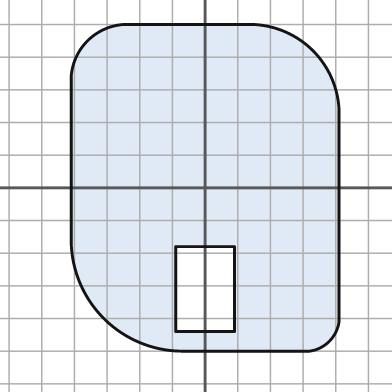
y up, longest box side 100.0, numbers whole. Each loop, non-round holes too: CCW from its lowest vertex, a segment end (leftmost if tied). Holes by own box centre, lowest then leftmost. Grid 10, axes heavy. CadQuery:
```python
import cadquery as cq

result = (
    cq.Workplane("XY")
    .moveTo(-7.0, -50.0)
    .lineTo(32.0, -50.0)
    .threePointArc((38.0, -47.0), (41.0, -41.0))
    .lineTo(41.0, 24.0)
    .threePointArc((33.0, 42.0), (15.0, 50.0))
    .lineTo(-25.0, 50.0)
    .threePointArc((-36.0, 45.0), (-41.0, 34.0))
    .lineTo(-41.0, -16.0)
    .threePointArc((-31.0, -40.0), (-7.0, -50.0))
    .close()
    .moveTo(-9.0, -44.0)
    .lineTo(9.0, -44.0)
    .lineTo(9.0, -18.0)
    .lineTo(-9.0, -18.0)
    .close()
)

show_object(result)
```